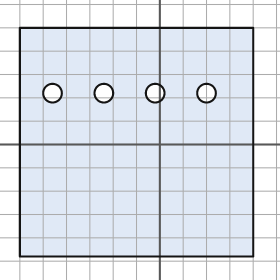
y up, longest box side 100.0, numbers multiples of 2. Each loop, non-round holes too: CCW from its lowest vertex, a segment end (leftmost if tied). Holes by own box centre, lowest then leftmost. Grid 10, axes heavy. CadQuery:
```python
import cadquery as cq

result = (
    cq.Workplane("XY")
    .moveTo(-60.0, -48.0)
    .lineTo(40.0, -48.0)
    .lineTo(40.0, 50.0)
    .lineTo(-60.0, 50.0)
    .close()
    .moveTo(-46.0, 22.0)
    .circle(4.0)
    .moveTo(-24.0, 22.0)
    .circle(4.0)
    .moveTo(-2.0, 22.0)
    .circle(4.0)
    .moveTo(20.0, 22.0)
    .circle(4.0)
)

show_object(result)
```